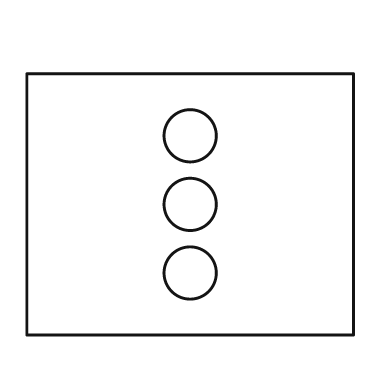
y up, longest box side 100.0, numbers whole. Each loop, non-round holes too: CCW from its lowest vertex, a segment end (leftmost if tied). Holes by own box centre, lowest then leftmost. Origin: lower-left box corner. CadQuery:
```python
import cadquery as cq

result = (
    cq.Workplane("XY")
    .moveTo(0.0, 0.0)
    .lineTo(100.0, 0.0)
    .lineTo(100.0, 80.0)
    .lineTo(0.0, 80.0)
    .close()
    .moveTo(50.0, 19.0)
    .circle(8.0)
    .moveTo(50.0, 40.0)
    .circle(8.0)
    .moveTo(50.0, 61.0)
    .circle(8.0)
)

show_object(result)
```